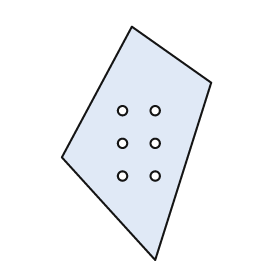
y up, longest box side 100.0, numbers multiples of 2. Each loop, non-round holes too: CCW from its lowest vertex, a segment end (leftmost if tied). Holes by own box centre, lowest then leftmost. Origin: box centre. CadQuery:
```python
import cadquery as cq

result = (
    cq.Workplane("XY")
    .moveTo(8.0, -50.0)
    .lineTo(32.0, 26.0)
    .lineTo(-2.0, 50.0)
    .lineTo(-32.0, -6.0)
    .close()
    .moveTo(-6.0, -14.0)
    .circle(2.0)
    .moveTo(8.0, -14.0)
    .circle(2.0)
    .moveTo(-6.0, 0.0)
    .circle(2.0)
    .moveTo(8.0, 0.0)
    .circle(2.0)
    .moveTo(-6.0, 14.0)
    .circle(2.0)
    .moveTo(8.0, 14.0)
    .circle(2.0)
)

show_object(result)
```